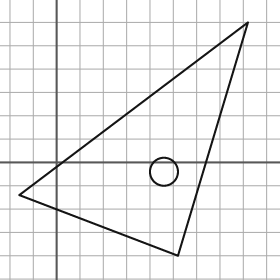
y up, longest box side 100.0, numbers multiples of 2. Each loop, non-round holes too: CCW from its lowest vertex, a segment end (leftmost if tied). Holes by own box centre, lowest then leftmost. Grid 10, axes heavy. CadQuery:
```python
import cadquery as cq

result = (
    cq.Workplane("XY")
    .moveTo(52.0, -40.0)
    .lineTo(82.0, 60.0)
    .lineTo(-16.0, -14.0)
    .close()
    .moveTo(46.0, -4.0)
    .circle(6.0)
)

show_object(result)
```